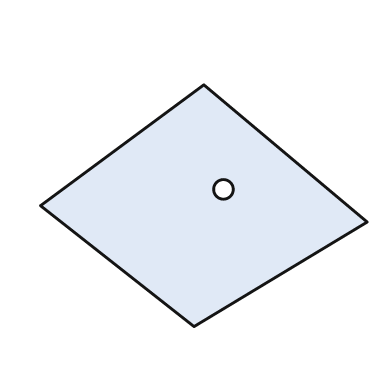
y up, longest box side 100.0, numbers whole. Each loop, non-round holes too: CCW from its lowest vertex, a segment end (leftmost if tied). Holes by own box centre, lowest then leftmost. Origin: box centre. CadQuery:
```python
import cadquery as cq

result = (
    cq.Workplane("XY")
    .moveTo(-3.0, -37.0)
    .lineTo(50.0, -5.0)
    .lineTo(0.0, 37.0)
    .lineTo(-50.0, 0.0)
    .close()
    .moveTo(6.0, 5.0)
    .circle(3.0)
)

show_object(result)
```